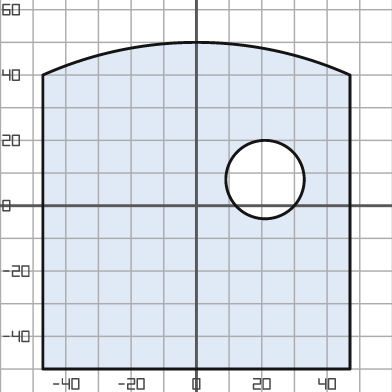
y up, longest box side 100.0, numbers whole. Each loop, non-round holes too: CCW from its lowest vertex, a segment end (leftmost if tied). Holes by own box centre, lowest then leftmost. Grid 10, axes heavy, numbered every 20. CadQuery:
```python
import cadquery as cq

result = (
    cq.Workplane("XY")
    .moveTo(-47.0, -50.0)
    .lineTo(47.0, -50.0)
    .lineTo(47.0, 40.0)
    .threePointArc((0.0, 50.0), (-47.0, 40.0))
    .close()
    .moveTo(21.0, 8.0)
    .circle(12.0)
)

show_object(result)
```